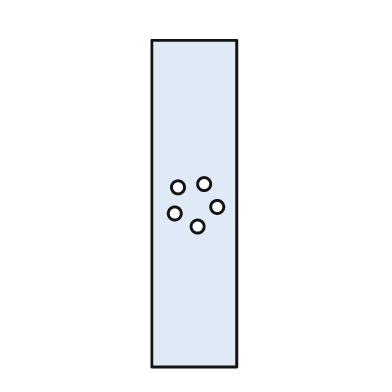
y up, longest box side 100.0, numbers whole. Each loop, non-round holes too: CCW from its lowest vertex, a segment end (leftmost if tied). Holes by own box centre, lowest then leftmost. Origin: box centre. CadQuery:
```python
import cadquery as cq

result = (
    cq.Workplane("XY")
    .moveTo(-13.0, -50.0)
    .lineTo(13.0, -50.0)
    .lineTo(13.0, 50.0)
    .lineTo(-13.0, 50.0)
    .close()
    .moveTo(1.0, -7.0)
    .circle(2.0)
    .moveTo(-6.0, -3.0)
    .circle(2.0)
    .moveTo(7.0, -1.0)
    .circle(2.0)
    .moveTo(-5.0, 5.0)
    .circle(2.0)
    .moveTo(3.0, 6.0)
    .circle(2.0)
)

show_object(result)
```